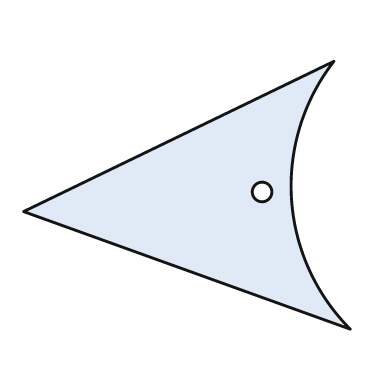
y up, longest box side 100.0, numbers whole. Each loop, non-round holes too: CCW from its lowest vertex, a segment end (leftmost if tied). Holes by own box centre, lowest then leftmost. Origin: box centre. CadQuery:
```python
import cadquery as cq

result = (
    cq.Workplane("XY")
    .moveTo(50.0, -41.0)
    .threePointArc((32.0, -1.0), (45.0, 41.0))
    .lineTo(-50.0, -5.0)
    .close()
    .moveTo(23.0, 1.0)
    .circle(3.0)
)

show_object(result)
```